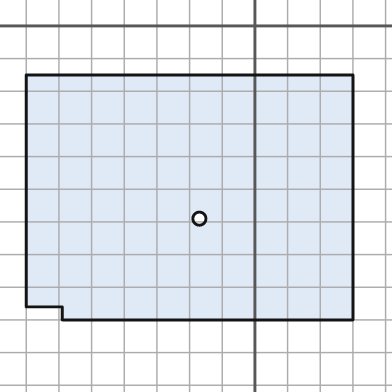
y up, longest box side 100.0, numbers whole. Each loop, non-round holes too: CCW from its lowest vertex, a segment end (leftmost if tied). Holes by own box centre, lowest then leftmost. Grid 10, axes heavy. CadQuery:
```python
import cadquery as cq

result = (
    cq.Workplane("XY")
    .moveTo(-59.0, -90.0)
    .lineTo(30.0, -90.0)
    .lineTo(30.0, -15.0)
    .lineTo(-70.0, -15.0)
    .lineTo(-70.0, -86.0)
    .lineTo(-59.0, -86.0)
    .close()
    .moveTo(-17.0, -59.0)
    .circle(2.0)
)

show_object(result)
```